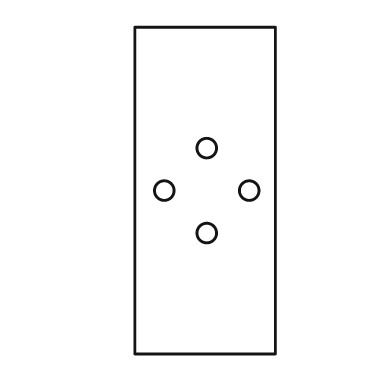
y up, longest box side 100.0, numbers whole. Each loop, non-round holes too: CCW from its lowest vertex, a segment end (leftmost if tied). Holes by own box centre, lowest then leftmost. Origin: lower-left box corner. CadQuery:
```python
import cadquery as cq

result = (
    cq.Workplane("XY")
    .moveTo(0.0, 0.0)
    .lineTo(43.0, 0.0)
    .lineTo(43.0, 100.0)
    .lineTo(0.0, 100.0)
    .close()
    .moveTo(22.0, 37.0)
    .circle(3.0)
    .moveTo(9.0, 50.0)
    .circle(3.0)
    .moveTo(35.0, 50.0)
    .circle(3.0)
    .moveTo(22.0, 63.0)
    .circle(3.0)
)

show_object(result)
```